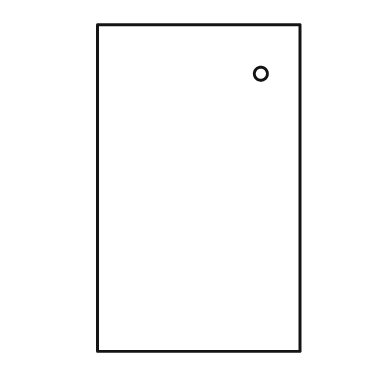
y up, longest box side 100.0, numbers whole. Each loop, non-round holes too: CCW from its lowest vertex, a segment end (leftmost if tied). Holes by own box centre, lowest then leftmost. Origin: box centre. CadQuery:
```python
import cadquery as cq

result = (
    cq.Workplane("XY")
    .moveTo(-31.0, -50.0)
    .lineTo(31.0, -50.0)
    .lineTo(31.0, 50.0)
    .lineTo(-31.0, 50.0)
    .close()
    .moveTo(19.0, 35.0)
    .circle(2.0)
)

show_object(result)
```